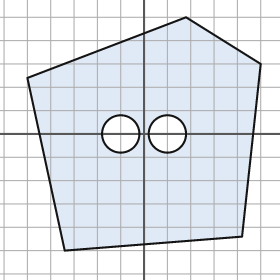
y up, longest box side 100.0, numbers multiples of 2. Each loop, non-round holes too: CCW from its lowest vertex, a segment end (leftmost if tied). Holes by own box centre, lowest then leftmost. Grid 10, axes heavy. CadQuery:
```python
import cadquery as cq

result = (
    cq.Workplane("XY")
    .moveTo(-34.0, -50.0)
    .lineTo(42.0, -44.0)
    .lineTo(50.0, 30.0)
    .lineTo(18.0, 50.0)
    .lineTo(-50.0, 24.0)
    .close()
    .moveTo(-10.0, 0.0)
    .circle(8.0)
    .moveTo(10.0, 0.0)
    .circle(8.0)
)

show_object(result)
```